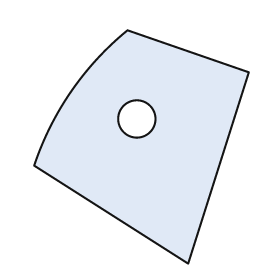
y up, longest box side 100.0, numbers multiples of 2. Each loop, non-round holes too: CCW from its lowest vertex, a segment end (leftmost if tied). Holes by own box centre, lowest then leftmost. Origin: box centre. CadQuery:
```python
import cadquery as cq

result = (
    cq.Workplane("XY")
    .moveTo(20.0, -50.0)
    .lineTo(46.0, 32.0)
    .lineTo(-6.0, 50.0)
    .threePointArc((-30.0, 24.0), (-46.0, -8.0))
    .close()
    .moveTo(-2.0, 12.0)
    .circle(8.0)
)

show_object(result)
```